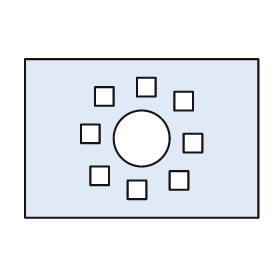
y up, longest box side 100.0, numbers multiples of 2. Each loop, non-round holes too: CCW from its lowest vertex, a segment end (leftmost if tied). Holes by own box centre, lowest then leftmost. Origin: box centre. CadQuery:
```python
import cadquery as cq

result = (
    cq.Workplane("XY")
    .moveTo(-50.0, -34.0)
    .lineTo(50.0, -34.0)
    .lineTo(50.0, 34.0)
    .lineTo(-50.0, 34.0)
    .close()
    .moveTo(-6.0, -26.0)
    .lineTo(2.0, -26.0)
    .lineTo(2.0, -18.0)
    .lineTo(-6.0, -18.0)
    .close()
    .moveTo(12.0, -22.0)
    .lineTo(20.0, -22.0)
    .lineTo(20.0, -14.0)
    .lineTo(12.0, -14.0)
    .close()
    .moveTo(-22.0, -20.0)
    .lineTo(-14.0, -20.0)
    .lineTo(-14.0, -12.0)
    .lineTo(-22.0, -12.0)
    .close()
    .moveTo(18.0, -6.0)
    .lineTo(26.0, -6.0)
    .lineTo(26.0, 2.0)
    .lineTo(18.0, 2.0)
    .close()
    .moveTo(0.0, 0.0)
    .circle(12.0)
    .moveTo(-26.0, -2.0)
    .lineTo(-18.0, -2.0)
    .lineTo(-18.0, 6.0)
    .lineTo(-26.0, 6.0)
    .close()
    .moveTo(14.0, 12.0)
    .lineTo(22.0, 12.0)
    .lineTo(22.0, 20.0)
    .lineTo(14.0, 20.0)
    .close()
    .moveTo(-20.0, 14.0)
    .lineTo(-12.0, 14.0)
    .lineTo(-12.0, 22.0)
    .lineTo(-20.0, 22.0)
    .close()
    .moveTo(-2.0, 18.0)
    .lineTo(6.0, 18.0)
    .lineTo(6.0, 26.0)
    .lineTo(-2.0, 26.0)
    .close()
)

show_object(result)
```